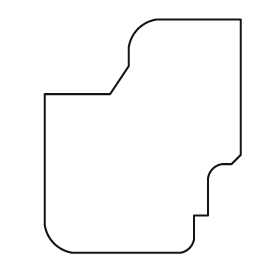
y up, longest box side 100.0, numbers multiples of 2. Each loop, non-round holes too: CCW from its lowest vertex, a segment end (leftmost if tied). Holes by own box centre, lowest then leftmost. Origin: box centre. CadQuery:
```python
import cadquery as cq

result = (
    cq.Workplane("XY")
    .moveTo(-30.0, -50.0)
    .lineTo(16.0, -50.0)
    .threePointArc((20.0, -48.0), (22.0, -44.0))
    .lineTo(22.0, -34.0)
    .lineTo(28.0, -34.0)
    .lineTo(28.0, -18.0)
    .threePointArc((30.0, -14.0), (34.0, -12.0))
    .lineTo(38.0, -12.0)
    .lineTo(42.0, -8.0)
    .lineTo(42.0, 50.0)
    .lineTo(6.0, 50.0)
    .threePointArc((-2.0, 46.0), (-6.0, 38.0))
    .lineTo(-6.0, 30.0)
    .lineTo(-14.0, 18.0)
    .lineTo(-42.0, 18.0)
    .lineTo(-42.0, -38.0)
    .threePointArc((-38.0, -46.0), (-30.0, -50.0))
    .close()
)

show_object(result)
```